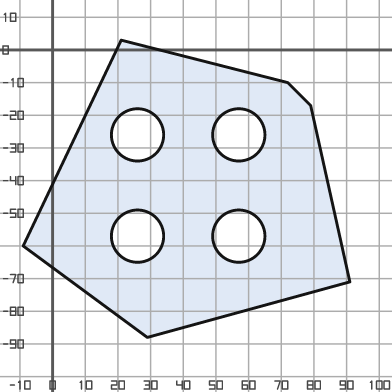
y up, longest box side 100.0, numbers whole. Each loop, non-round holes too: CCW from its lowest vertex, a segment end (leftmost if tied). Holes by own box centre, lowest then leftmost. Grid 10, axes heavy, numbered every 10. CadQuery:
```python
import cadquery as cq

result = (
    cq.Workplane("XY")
    .moveTo(29.0, -88.0)
    .lineTo(91.0, -71.0)
    .lineTo(79.0, -17.0)
    .lineTo(72.0, -10.0)
    .lineTo(21.0, 3.0)
    .lineTo(-9.0, -60.0)
    .close()
    .moveTo(26.0, -57.0)
    .circle(8.0)
    .moveTo(57.0, -57.0)
    .circle(8.0)
    .moveTo(26.0, -26.0)
    .circle(8.0)
    .moveTo(57.0, -26.0)
    .circle(8.0)
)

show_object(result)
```